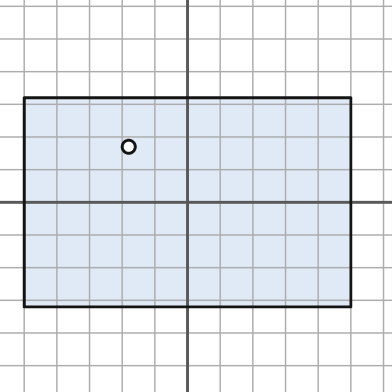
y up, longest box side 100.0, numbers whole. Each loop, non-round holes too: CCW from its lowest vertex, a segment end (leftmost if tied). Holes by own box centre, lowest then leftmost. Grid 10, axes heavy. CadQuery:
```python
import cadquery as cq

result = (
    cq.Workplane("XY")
    .moveTo(-50.0, -32.0)
    .lineTo(50.0, -32.0)
    .lineTo(50.0, 32.0)
    .lineTo(-50.0, 32.0)
    .close()
    .moveTo(-18.0, 17.0)
    .circle(2.0)
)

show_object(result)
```